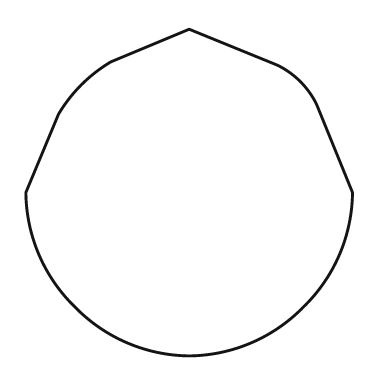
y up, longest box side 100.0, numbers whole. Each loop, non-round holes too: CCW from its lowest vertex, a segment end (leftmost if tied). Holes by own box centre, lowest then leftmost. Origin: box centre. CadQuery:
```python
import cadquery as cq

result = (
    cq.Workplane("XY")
    .moveTo(0.0, -50.0)
    .threePointArc((19.0, -46.0), (35.0, -35.0))
    .threePointArc((46.0, -19.0), (50.0, 0.0))
    .lineTo(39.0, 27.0)
    .threePointArc((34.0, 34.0), (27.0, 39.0))
    .lineTo(0.0, 50.0)
    .lineTo(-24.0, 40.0)
    .threePointArc((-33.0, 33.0), (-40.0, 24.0))
    .lineTo(-50.0, 0.0)
    .threePointArc((-46.0, -19.0), (-35.0, -35.0))
    .threePointArc((-19.0, -46.0), (0.0, -50.0))
    .close()
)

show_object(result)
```